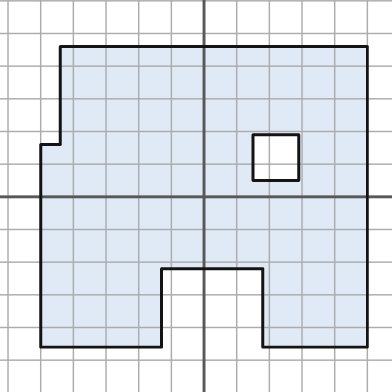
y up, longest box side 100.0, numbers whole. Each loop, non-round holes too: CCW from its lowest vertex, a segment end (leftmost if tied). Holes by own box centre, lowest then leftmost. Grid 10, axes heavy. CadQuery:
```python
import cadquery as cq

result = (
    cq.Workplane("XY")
    .moveTo(-50.0, -46.0)
    .lineTo(-13.0, -46.0)
    .lineTo(-13.0, -22.0)
    .lineTo(18.0, -22.0)
    .lineTo(18.0, -46.0)
    .lineTo(50.0, -46.0)
    .lineTo(50.0, 46.0)
    .lineTo(-44.0, 46.0)
    .lineTo(-44.0, 16.0)
    .lineTo(-50.0, 16.0)
    .close()
    .moveTo(15.0, 5.0)
    .lineTo(29.0, 5.0)
    .lineTo(29.0, 19.0)
    .lineTo(15.0, 19.0)
    .close()
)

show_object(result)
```